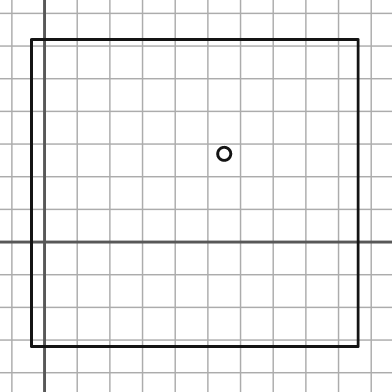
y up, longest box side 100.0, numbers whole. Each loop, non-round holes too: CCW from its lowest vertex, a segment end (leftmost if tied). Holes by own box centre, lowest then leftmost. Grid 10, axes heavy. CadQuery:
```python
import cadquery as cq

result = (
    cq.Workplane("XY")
    .moveTo(-4.0, -32.0)
    .lineTo(96.0, -32.0)
    .lineTo(96.0, 62.0)
    .lineTo(-4.0, 62.0)
    .close()
    .moveTo(55.0, 27.0)
    .circle(2.0)
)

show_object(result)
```